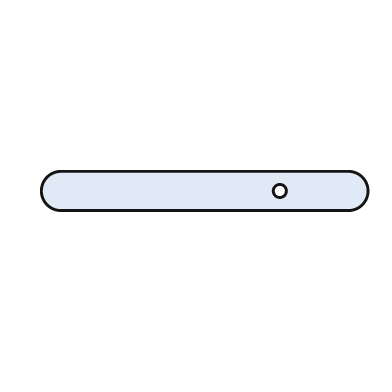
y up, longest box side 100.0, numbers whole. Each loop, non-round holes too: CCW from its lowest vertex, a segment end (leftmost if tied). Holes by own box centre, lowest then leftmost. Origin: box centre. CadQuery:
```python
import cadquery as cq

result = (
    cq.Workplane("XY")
    .moveTo(-44.0, -6.0)
    .lineTo(44.0, -6.0)
    .threePointArc((50.0, 0.0), (44.0, 6.0))
    .lineTo(-44.0, 6.0)
    .threePointArc((-50.0, 0.0), (-44.0, -6.0))
    .close()
    .moveTo(23.0, 0.0)
    .circle(2.0)
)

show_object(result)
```